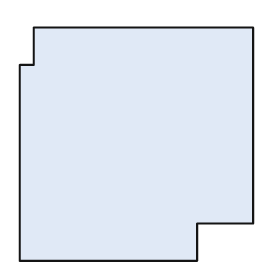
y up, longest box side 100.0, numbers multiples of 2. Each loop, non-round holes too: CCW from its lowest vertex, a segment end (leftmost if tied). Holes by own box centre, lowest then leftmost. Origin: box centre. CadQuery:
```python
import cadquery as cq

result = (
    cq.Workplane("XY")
    .moveTo(-50.0, -50.0)
    .lineTo(26.0, -50.0)
    .lineTo(26.0, -34.0)
    .lineTo(50.0, -34.0)
    .lineTo(50.0, 50.0)
    .lineTo(-44.0, 50.0)
    .lineTo(-44.0, 34.0)
    .lineTo(-50.0, 34.0)
    .close()
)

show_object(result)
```